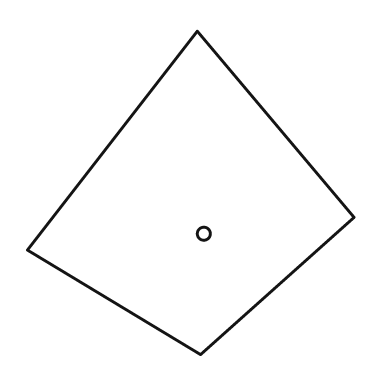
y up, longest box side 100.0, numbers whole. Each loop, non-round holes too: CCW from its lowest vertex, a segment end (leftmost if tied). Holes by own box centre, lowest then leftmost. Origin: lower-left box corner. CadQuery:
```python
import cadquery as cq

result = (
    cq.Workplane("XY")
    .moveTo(53.0, 0.0)
    .lineTo(100.0, 42.0)
    .lineTo(52.0, 99.0)
    .lineTo(0.0, 32.0)
    .close()
    .moveTo(54.0, 37.0)
    .circle(2.0)
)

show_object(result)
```